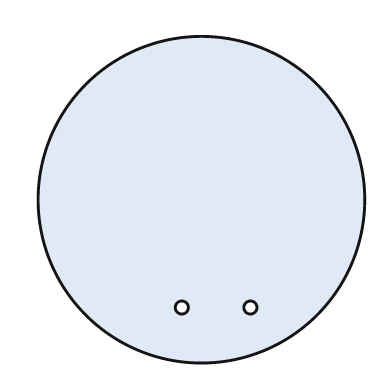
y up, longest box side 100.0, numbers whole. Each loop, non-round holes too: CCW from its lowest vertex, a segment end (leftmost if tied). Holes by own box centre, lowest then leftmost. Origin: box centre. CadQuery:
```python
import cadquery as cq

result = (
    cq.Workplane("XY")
    .moveTo(0.0, 0.0)
    .circle(50.0)
    .moveTo(-6.0, -33.0)
    .circle(2.0)
    .moveTo(15.0, -33.0)
    .circle(2.0)
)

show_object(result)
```